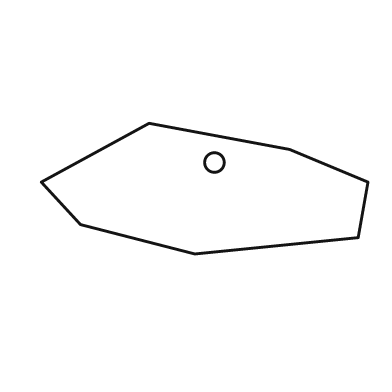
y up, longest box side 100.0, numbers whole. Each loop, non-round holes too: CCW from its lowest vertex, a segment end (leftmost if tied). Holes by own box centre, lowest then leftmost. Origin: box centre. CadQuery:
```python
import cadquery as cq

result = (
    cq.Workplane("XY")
    .moveTo(-3.0, -20.0)
    .lineTo(47.0, -15.0)
    .lineTo(50.0, 2.0)
    .lineTo(26.0, 12.0)
    .lineTo(-17.0, 20.0)
    .lineTo(-50.0, 2.0)
    .lineTo(-38.0, -11.0)
    .close()
    .moveTo(3.0, 8.0)
    .circle(3.0)
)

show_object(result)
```